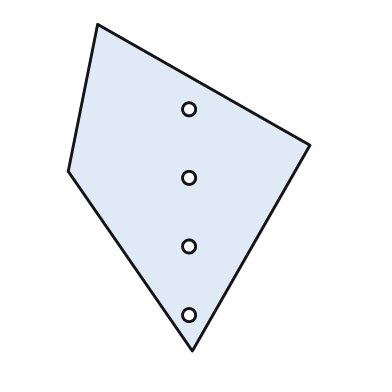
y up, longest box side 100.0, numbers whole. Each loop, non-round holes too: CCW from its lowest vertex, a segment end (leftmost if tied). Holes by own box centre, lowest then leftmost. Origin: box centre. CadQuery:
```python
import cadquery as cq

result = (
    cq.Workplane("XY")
    .moveTo(1.0, -50.0)
    .lineTo(37.0, 13.0)
    .lineTo(-28.0, 50.0)
    .lineTo(-37.0, 5.0)
    .close()
    .moveTo(0.0, -39.0)
    .circle(2.0)
    .moveTo(0.0, -18.0)
    .circle(2.0)
    .moveTo(0.0, 3.0)
    .circle(2.0)
    .moveTo(0.0, 24.0)
    .circle(2.0)
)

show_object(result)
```